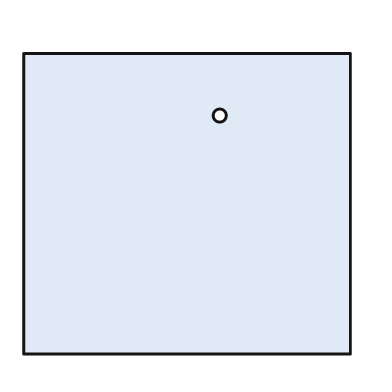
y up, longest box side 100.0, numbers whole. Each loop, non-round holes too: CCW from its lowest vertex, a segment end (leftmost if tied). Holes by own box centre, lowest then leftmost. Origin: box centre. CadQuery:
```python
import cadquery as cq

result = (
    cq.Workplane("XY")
    .moveTo(-50.0, -46.0)
    .lineTo(50.0, -46.0)
    .lineTo(50.0, 46.0)
    .lineTo(-50.0, 46.0)
    .close()
    .moveTo(10.0, 27.0)
    .circle(2.0)
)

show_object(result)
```